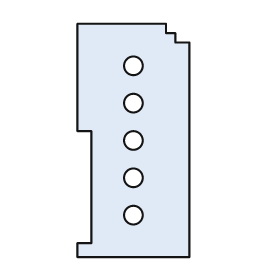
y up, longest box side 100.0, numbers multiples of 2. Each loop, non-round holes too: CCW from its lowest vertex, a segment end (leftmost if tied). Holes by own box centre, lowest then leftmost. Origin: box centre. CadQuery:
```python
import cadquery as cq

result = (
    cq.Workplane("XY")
    .moveTo(-24.0, -50.0)
    .lineTo(24.0, -50.0)
    .lineTo(24.0, 42.0)
    .lineTo(18.0, 42.0)
    .lineTo(18.0, 46.0)
    .lineTo(14.0, 46.0)
    .lineTo(14.0, 50.0)
    .lineTo(-24.0, 50.0)
    .lineTo(-24.0, 4.0)
    .lineTo(-18.0, 4.0)
    .lineTo(-18.0, -44.0)
    .lineTo(-24.0, -44.0)
    .close()
    .moveTo(0.0, -32.0)
    .circle(4.0)
    .moveTo(0.0, -16.0)
    .circle(4.0)
    .moveTo(0.0, 0.0)
    .circle(4.0)
    .moveTo(0.0, 16.0)
    .circle(4.0)
    .moveTo(0.0, 32.0)
    .circle(4.0)
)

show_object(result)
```